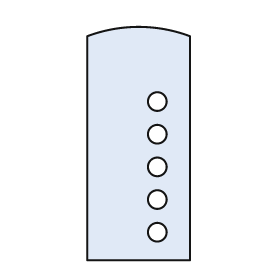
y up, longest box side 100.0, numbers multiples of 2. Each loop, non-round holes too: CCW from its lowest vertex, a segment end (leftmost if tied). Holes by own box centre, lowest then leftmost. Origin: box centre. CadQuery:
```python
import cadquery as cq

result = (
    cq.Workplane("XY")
    .moveTo(-22.0, -50.0)
    .lineTo(22.0, -50.0)
    .lineTo(22.0, 46.0)
    .threePointArc((0.0, 50.0), (-22.0, 46.0))
    .close()
    .moveTo(8.0, -38.0)
    .circle(4.0)
    .moveTo(8.0, -24.0)
    .circle(4.0)
    .moveTo(8.0, -10.0)
    .circle(4.0)
    .moveTo(8.0, 4.0)
    .circle(4.0)
    .moveTo(8.0, 18.0)
    .circle(4.0)
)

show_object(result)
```